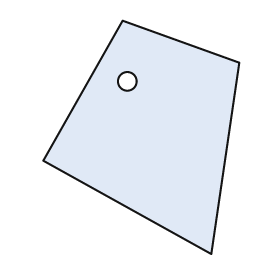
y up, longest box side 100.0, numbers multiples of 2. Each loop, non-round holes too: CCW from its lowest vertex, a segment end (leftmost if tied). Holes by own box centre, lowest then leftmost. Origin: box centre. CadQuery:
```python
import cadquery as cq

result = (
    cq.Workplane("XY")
    .moveTo(30.0, -50.0)
    .lineTo(42.0, 32.0)
    .lineTo(-8.0, 50.0)
    .lineTo(-42.0, -10.0)
    .close()
    .moveTo(-6.0, 24.0)
    .circle(4.0)
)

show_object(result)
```